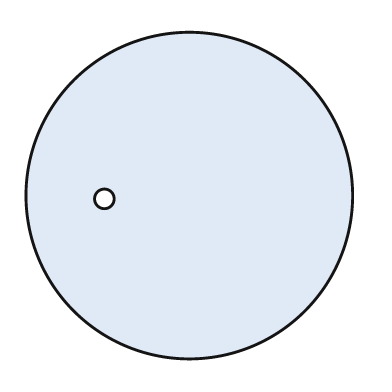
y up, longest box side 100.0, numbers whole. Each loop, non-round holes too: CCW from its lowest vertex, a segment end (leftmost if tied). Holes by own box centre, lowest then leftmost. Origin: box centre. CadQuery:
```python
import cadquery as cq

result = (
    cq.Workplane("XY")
    .moveTo(0.0, 0.0)
    .circle(50.0)
    .moveTo(-26.0, -1.0)
    .circle(3.0)
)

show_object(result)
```